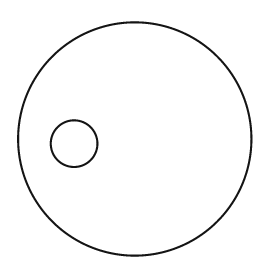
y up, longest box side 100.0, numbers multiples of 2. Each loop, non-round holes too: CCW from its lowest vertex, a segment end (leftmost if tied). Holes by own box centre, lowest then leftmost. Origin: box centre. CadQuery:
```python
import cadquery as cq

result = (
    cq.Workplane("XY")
    .moveTo(0.0, 0.0)
    .circle(50.0)
    .moveTo(-26.0, -2.0)
    .circle(10.0)
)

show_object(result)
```